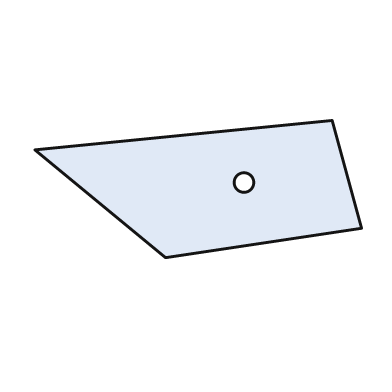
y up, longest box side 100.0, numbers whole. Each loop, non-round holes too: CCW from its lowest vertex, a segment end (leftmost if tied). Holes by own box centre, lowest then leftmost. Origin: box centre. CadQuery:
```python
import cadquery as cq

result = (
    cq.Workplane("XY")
    .moveTo(-10.0, -21.0)
    .lineTo(50.0, -12.0)
    .lineTo(41.0, 21.0)
    .lineTo(-50.0, 12.0)
    .close()
    .moveTo(14.0, 2.0)
    .circle(3.0)
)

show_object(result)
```